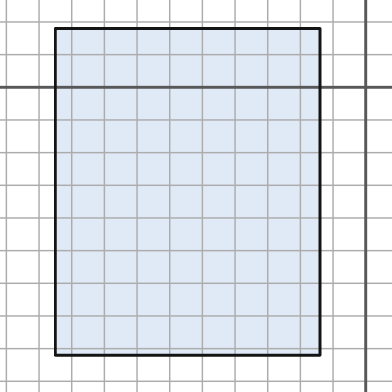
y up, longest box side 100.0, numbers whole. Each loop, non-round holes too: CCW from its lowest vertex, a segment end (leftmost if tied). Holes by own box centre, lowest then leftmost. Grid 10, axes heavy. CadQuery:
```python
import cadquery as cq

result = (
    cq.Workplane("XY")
    .moveTo(-95.0, -82.0)
    .lineTo(-14.0, -82.0)
    .lineTo(-14.0, 18.0)
    .lineTo(-95.0, 18.0)
    .close()
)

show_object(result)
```